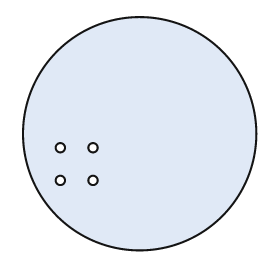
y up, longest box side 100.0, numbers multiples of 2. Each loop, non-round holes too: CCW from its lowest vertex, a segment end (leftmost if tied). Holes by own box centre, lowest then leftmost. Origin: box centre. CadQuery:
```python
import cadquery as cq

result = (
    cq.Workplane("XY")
    .moveTo(0.0, 0.0)
    .circle(50.0)
    .moveTo(-34.0, -20.0)
    .circle(2.0)
    .moveTo(-20.0, -20.0)
    .circle(2.0)
    .moveTo(-34.0, -6.0)
    .circle(2.0)
    .moveTo(-20.0, -6.0)
    .circle(2.0)
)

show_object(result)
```